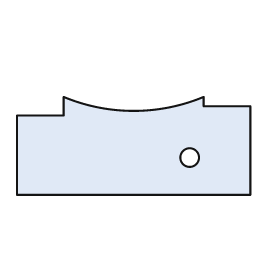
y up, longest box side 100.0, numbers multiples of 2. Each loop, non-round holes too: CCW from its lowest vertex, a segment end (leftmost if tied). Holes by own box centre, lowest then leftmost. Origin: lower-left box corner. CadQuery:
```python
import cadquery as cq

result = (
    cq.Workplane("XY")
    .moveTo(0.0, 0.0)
    .lineTo(100.0, 0.0)
    .lineTo(100.0, 38.0)
    .lineTo(80.0, 38.0)
    .lineTo(80.0, 42.0)
    .threePointArc((50.0, 36.0), (20.0, 42.0))
    .lineTo(20.0, 34.0)
    .lineTo(0.0, 34.0)
    .close()
    .moveTo(74.0, 16.0)
    .circle(4.0)
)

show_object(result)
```